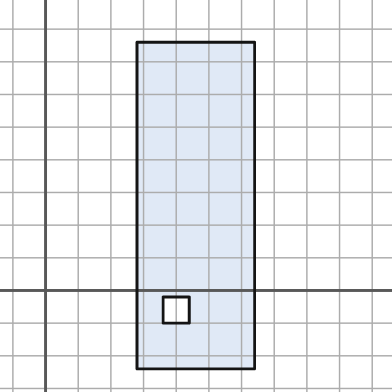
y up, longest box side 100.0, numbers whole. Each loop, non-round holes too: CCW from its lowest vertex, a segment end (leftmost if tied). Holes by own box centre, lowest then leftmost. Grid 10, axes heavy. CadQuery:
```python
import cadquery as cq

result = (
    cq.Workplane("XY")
    .moveTo(28.0, -24.0)
    .lineTo(64.0, -24.0)
    .lineTo(64.0, 76.0)
    .lineTo(28.0, 76.0)
    .close()
    .moveTo(36.0, -10.0)
    .lineTo(44.0, -10.0)
    .lineTo(44.0, -2.0)
    .lineTo(36.0, -2.0)
    .close()
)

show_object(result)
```